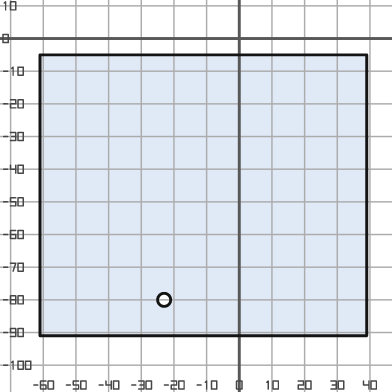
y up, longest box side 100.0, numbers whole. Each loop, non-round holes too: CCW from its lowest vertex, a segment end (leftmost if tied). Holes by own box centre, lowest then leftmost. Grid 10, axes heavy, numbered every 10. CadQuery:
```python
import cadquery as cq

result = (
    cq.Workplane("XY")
    .moveTo(-61.0, -91.0)
    .lineTo(39.0, -91.0)
    .lineTo(39.0, -5.0)
    .lineTo(-61.0, -5.0)
    .close()
    .moveTo(-23.0, -80.0)
    .circle(2.0)
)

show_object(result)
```